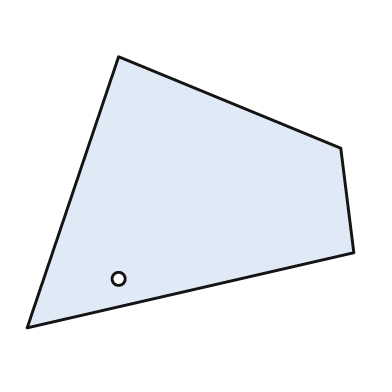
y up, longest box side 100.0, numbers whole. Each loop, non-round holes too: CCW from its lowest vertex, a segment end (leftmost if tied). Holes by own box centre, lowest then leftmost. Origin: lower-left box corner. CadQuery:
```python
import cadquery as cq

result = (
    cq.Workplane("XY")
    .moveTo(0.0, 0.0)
    .lineTo(100.0, 23.0)
    .lineTo(96.0, 55.0)
    .lineTo(28.0, 83.0)
    .close()
    .moveTo(28.0, 15.0)
    .circle(2.0)
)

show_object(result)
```